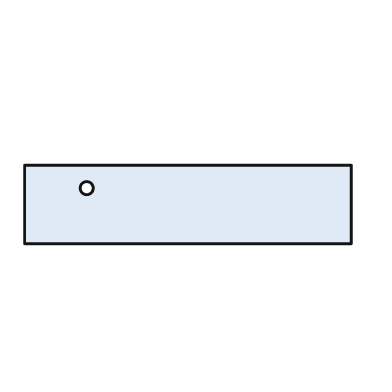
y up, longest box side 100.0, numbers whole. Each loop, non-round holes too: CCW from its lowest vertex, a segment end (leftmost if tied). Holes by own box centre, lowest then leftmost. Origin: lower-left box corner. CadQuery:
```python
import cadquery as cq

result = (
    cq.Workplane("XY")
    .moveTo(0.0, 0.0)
    .lineTo(100.0, 0.0)
    .lineTo(100.0, 24.0)
    .lineTo(0.0, 24.0)
    .close()
    .moveTo(19.0, 17.0)
    .circle(2.0)
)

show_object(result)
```